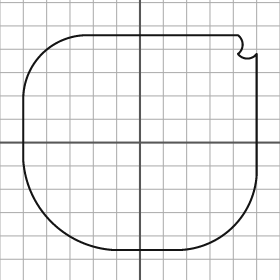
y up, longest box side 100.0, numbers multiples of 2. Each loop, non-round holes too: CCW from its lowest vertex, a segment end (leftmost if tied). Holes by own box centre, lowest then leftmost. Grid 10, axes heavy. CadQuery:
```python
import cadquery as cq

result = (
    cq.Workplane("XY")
    .moveTo(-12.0, -46.0)
    .lineTo(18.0, -46.0)
    .threePointArc((40.0, -36.0), (50.0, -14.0))
    .lineTo(50.0, 38.0)
    .threePointArc((46.0, 36.0), (42.0, 38.0))
    .threePointArc((44.0, 42.0), (42.0, 46.0))
    .lineTo(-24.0, 46.0)
    .threePointArc((-42.0, 38.0), (-50.0, 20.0))
    .lineTo(-50.0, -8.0)
    .threePointArc((-38.0, -34.0), (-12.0, -46.0))
    .close()
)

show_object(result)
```